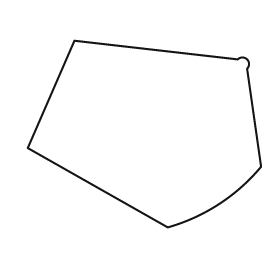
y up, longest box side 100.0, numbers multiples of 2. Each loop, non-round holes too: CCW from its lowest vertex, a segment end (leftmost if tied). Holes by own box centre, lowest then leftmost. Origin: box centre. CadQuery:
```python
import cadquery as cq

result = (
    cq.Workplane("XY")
    .moveTo(10.0, -40.0)
    .threePointArc((32.0, -30.0), (50.0, -14.0))
    .lineTo(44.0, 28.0)
    .threePointArc((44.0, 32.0), (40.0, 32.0))
    .lineTo(-30.0, 40.0)
    .lineTo(-50.0, -6.0)
    .close()
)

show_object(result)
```